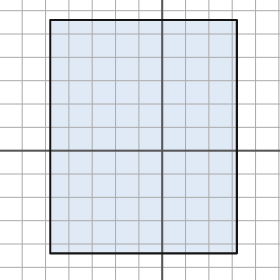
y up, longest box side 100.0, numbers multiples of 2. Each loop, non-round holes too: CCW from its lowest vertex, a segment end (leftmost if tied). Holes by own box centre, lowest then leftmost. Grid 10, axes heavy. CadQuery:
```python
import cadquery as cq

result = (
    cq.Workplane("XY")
    .moveTo(-48.0, -44.0)
    .lineTo(32.0, -44.0)
    .lineTo(32.0, 56.0)
    .lineTo(-48.0, 56.0)
    .close()
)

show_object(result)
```